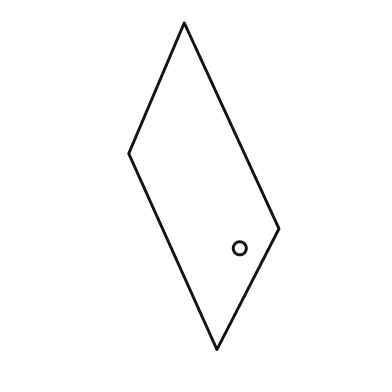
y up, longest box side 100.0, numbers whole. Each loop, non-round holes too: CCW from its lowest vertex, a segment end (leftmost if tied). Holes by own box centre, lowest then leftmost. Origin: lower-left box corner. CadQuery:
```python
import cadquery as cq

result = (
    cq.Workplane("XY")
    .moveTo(27.0, 0.0)
    .lineTo(46.0, 37.0)
    .lineTo(17.0, 100.0)
    .lineTo(0.0, 60.0)
    .close()
    .moveTo(34.0, 31.0)
    .circle(2.0)
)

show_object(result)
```